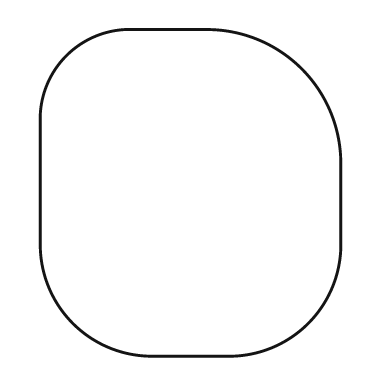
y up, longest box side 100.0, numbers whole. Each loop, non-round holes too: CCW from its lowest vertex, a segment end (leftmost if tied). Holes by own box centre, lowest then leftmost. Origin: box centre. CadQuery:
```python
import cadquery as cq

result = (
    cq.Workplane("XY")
    .moveTo(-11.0, -50.0)
    .lineTo(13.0, -50.0)
    .threePointArc((36.0, -40.0), (46.0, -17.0))
    .lineTo(46.0, 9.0)
    .threePointArc((34.0, 38.0), (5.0, 50.0))
    .lineTo(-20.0, 50.0)
    .threePointArc((-38.0, 42.0), (-46.0, 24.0))
    .lineTo(-46.0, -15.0)
    .threePointArc((-36.0, -40.0), (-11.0, -50.0))
    .close()
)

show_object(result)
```